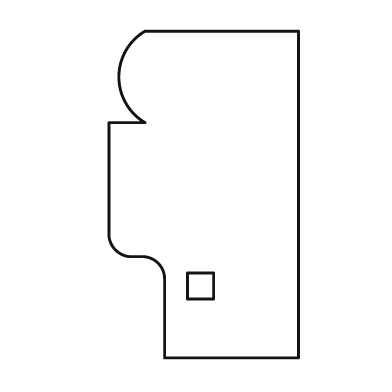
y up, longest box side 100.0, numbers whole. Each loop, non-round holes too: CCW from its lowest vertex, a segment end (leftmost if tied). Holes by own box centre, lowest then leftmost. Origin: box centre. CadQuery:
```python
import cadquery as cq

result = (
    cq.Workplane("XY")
    .moveTo(-12.0, -50.0)
    .lineTo(29.0, -50.0)
    .lineTo(29.0, 50.0)
    .lineTo(-18.0, 50.0)
    .threePointArc((-26.0, 36.0), (-18.0, 22.0))
    .lineTo(-29.0, 22.0)
    .lineTo(-29.0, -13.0)
    .threePointArc((-27.0, -17.0), (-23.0, -19.0))
    .lineTo(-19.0, -19.0)
    .threePointArc((-14.0, -21.0), (-12.0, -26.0))
    .close()
    .moveTo(-5.0, -32.0)
    .lineTo(3.0, -32.0)
    .lineTo(3.0, -24.0)
    .lineTo(-5.0, -24.0)
    .close()
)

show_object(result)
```